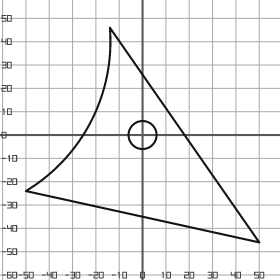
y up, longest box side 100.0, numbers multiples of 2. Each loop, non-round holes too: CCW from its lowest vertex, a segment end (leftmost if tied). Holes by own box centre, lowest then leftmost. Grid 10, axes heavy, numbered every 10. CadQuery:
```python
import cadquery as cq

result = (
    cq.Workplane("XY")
    .moveTo(50.0, -46.0)
    .lineTo(-14.0, 46.0)
    .threePointArc((-22.0, 6.0), (-50.0, -24.0))
    .close()
    .moveTo(0.0, 0.0)
    .circle(6.0)
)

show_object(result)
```